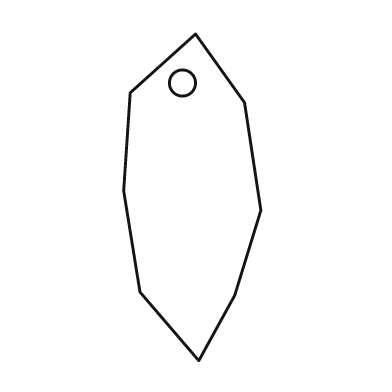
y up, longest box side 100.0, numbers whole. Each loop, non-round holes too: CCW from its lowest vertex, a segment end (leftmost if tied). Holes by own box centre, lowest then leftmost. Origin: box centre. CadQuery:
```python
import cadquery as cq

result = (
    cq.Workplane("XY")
    .moveTo(2.0, -50.0)
    .lineTo(13.0, -30.0)
    .lineTo(21.0, -4.0)
    .lineTo(16.0, 29.0)
    .lineTo(1.0, 50.0)
    .lineTo(-19.0, 32.0)
    .lineTo(-21.0, 2.0)
    .lineTo(-16.0, -29.0)
    .close()
    .moveTo(-3.0, 35.0)
    .circle(4.0)
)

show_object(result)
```